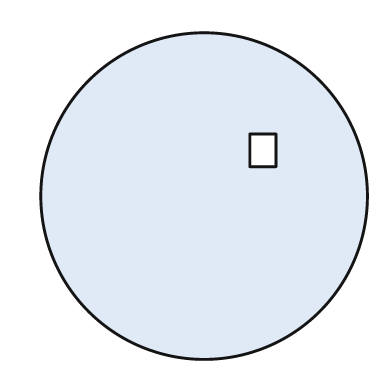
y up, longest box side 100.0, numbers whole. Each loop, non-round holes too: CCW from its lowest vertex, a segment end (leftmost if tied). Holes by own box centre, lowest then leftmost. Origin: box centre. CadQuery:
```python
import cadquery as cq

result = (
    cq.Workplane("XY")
    .moveTo(0.0, 0.0)
    .circle(50.0)
    .moveTo(14.0, 9.0)
    .lineTo(22.0, 9.0)
    .lineTo(22.0, 19.0)
    .lineTo(14.0, 19.0)
    .close()
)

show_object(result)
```